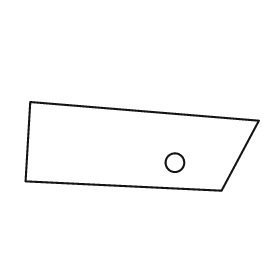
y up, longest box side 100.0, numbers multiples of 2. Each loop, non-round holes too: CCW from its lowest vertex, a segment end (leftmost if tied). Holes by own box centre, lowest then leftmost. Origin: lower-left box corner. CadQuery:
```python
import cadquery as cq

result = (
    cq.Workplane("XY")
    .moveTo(84.0, 0.0)
    .lineTo(100.0, 30.0)
    .lineTo(2.0, 38.0)
    .lineTo(0.0, 4.0)
    .close()
    .moveTo(64.0, 12.0)
    .circle(4.0)
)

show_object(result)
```